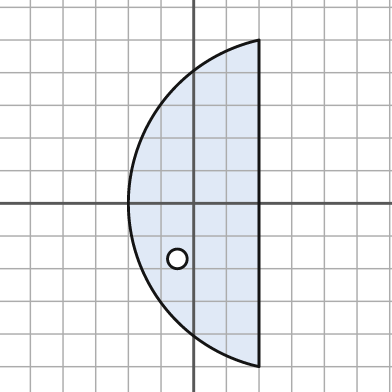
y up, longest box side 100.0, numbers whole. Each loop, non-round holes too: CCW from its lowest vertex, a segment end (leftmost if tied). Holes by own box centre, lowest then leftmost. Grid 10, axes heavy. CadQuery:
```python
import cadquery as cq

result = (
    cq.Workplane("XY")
    .moveTo(20.0, -50.0)
    .lineTo(20.0, 50.0)
    .threePointArc((-20.0, 0.0), (20.0, -50.0))
    .close()
    .moveTo(-5.0, -17.0)
    .circle(3.0)
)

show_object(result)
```